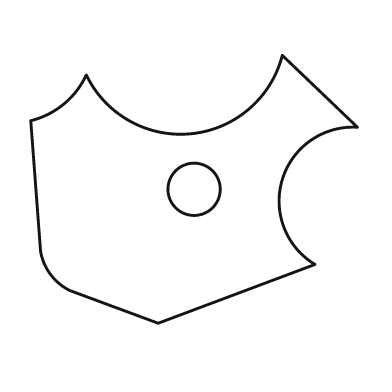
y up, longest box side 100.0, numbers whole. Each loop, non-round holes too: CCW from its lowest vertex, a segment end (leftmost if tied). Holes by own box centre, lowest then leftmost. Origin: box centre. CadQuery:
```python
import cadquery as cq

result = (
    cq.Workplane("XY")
    .moveTo(-11.0, -41.0)
    .lineTo(37.0, -23.0)
    .threePointArc((27.0, 3.0), (50.0, 19.0))
    .lineTo(27.0, 41.0)
    .threePointArc((-1.0, 17.0), (-33.0, 35.0))
    .threePointArc((-40.0, 26.0), (-50.0, 21.0))
    .lineTo(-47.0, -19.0)
    .threePointArc((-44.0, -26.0), (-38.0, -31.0))
    .close()
    .moveTo(0.0, 0.0)
    .circle(8.0)
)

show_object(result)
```